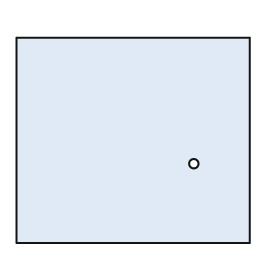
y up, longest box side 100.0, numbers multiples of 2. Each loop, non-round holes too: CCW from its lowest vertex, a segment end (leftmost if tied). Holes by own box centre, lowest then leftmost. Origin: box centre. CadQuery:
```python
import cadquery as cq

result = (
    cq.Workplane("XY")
    .moveTo(-50.0, -44.0)
    .lineTo(50.0, -44.0)
    .lineTo(50.0, 44.0)
    .lineTo(-50.0, 44.0)
    .close()
    .moveTo(26.0, -10.0)
    .circle(2.0)
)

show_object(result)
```